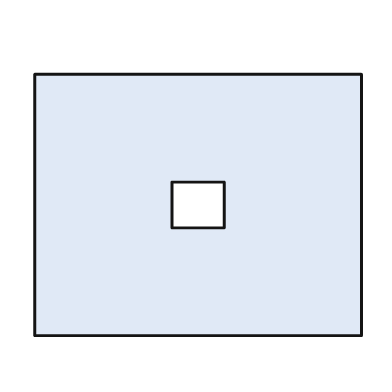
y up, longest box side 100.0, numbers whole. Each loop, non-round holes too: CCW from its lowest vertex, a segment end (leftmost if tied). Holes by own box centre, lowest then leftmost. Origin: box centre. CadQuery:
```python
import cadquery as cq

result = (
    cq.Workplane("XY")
    .moveTo(-50.0, -40.0)
    .lineTo(50.0, -40.0)
    .lineTo(50.0, 40.0)
    .lineTo(-50.0, 40.0)
    .close()
    .moveTo(-8.0, -7.0)
    .lineTo(8.0, -7.0)
    .lineTo(8.0, 7.0)
    .lineTo(-8.0, 7.0)
    .close()
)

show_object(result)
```